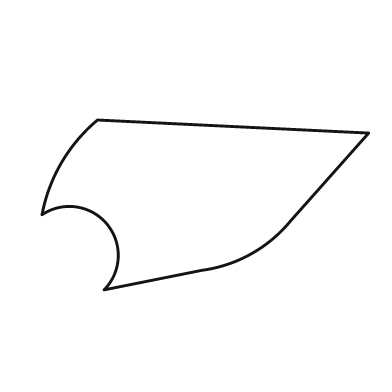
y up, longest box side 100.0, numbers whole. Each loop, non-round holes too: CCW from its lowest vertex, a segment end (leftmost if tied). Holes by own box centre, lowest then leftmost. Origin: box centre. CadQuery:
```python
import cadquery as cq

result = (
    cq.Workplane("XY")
    .moveTo(-31.0, -26.0)
    .lineTo(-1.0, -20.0)
    .threePointArc((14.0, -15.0), (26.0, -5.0))
    .lineTo(50.0, 22.0)
    .lineTo(-33.0, 26.0)
    .threePointArc((-44.0, 13.0), (-50.0, -3.0))
    .threePointArc((-30.0, -6.0), (-31.0, -26.0))
    .close()
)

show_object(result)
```